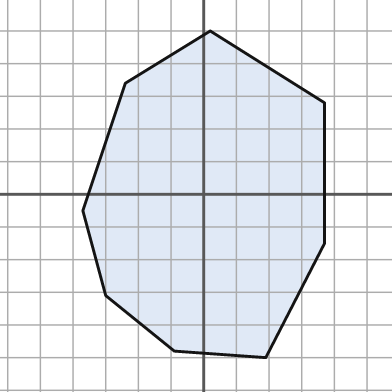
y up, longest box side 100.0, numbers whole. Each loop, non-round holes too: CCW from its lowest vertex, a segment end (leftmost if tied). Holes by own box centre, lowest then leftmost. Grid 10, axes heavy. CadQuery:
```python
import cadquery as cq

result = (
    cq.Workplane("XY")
    .moveTo(19.0, -50.0)
    .lineTo(37.0, -15.0)
    .lineTo(37.0, 28.0)
    .lineTo(2.0, 50.0)
    .lineTo(-24.0, 34.0)
    .lineTo(-37.0, -5.0)
    .lineTo(-30.0, -31.0)
    .lineTo(-9.0, -48.0)
    .close()
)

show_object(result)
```